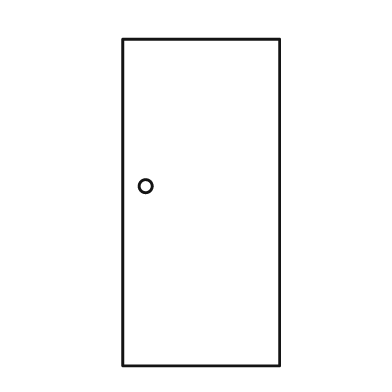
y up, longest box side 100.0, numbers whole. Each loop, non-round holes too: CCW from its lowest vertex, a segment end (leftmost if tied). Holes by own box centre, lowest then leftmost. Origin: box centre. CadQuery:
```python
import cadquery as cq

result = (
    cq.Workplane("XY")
    .moveTo(-24.0, -50.0)
    .lineTo(24.0, -50.0)
    .lineTo(24.0, 50.0)
    .lineTo(-24.0, 50.0)
    .close()
    .moveTo(-17.0, 5.0)
    .circle(2.0)
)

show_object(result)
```